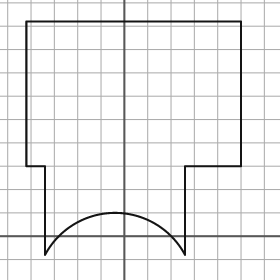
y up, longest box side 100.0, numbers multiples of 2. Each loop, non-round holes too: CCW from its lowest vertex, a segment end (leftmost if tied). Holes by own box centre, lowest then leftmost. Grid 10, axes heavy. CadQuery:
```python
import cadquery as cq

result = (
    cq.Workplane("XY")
    .moveTo(-34.0, -8.0)
    .threePointArc((-4.0, 10.0), (26.0, -8.0))
    .lineTo(26.0, 30.0)
    .lineTo(50.0, 30.0)
    .lineTo(50.0, 92.0)
    .lineTo(-42.0, 92.0)
    .lineTo(-42.0, 30.0)
    .lineTo(-34.0, 30.0)
    .close()
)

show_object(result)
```